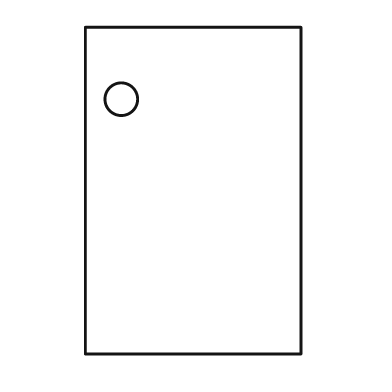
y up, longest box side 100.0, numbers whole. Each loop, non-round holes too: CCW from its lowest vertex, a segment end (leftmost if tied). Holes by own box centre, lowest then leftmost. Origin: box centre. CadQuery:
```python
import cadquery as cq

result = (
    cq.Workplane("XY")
    .moveTo(-33.0, -50.0)
    .lineTo(33.0, -50.0)
    .lineTo(33.0, 50.0)
    .lineTo(-33.0, 50.0)
    .close()
    .moveTo(-22.0, 28.0)
    .circle(5.0)
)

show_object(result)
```